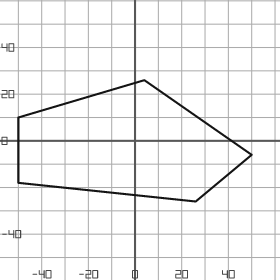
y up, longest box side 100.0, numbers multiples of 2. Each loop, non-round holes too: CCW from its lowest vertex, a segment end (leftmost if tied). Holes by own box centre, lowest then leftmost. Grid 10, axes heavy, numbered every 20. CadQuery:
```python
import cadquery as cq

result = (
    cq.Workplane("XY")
    .moveTo(26.0, -26.0)
    .lineTo(50.0, -6.0)
    .lineTo(4.0, 26.0)
    .lineTo(-50.0, 10.0)
    .lineTo(-50.0, -18.0)
    .close()
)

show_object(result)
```